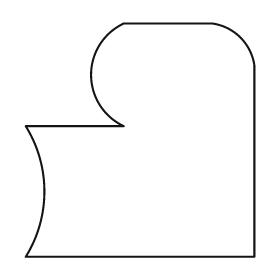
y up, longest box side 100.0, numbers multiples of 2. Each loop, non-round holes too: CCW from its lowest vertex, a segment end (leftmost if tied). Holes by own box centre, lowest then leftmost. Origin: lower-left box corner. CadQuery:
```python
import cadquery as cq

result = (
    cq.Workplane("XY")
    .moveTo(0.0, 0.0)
    .lineTo(98.0, 0.0)
    .lineTo(98.0, 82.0)
    .threePointArc((92.0, 94.0), (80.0, 100.0))
    .lineTo(42.0, 100.0)
    .threePointArc((28.0, 78.0), (42.0, 56.0))
    .lineTo(0.0, 56.0)
    .threePointArc((8.0, 28.0), (0.0, 0.0))
    .close()
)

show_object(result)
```